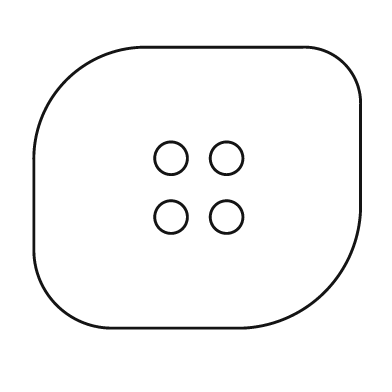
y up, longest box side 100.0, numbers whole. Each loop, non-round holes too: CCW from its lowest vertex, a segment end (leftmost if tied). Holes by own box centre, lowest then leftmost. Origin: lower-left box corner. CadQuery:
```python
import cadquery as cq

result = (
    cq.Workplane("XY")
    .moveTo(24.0, 0.0)
    .lineTo(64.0, 0.0)
    .threePointArc((89.0, 11.0), (100.0, 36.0))
    .lineTo(100.0, 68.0)
    .threePointArc((95.0, 81.0), (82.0, 86.0))
    .lineTo(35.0, 86.0)
    .threePointArc((10.0, 76.0), (0.0, 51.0))
    .lineTo(0.0, 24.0)
    .threePointArc((7.0, 7.0), (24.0, 0.0))
    .close()
    .moveTo(42.0, 34.0)
    .circle(5.0)
    .moveTo(59.0, 34.0)
    .circle(5.0)
    .moveTo(42.0, 52.0)
    .circle(5.0)
    .moveTo(59.0, 52.0)
    .circle(5.0)
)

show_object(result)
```